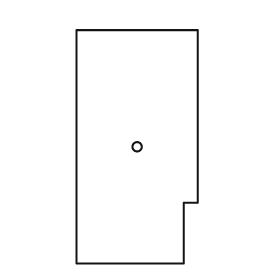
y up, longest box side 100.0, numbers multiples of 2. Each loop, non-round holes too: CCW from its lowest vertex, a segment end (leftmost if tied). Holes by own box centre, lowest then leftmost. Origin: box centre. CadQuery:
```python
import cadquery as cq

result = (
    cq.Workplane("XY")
    .moveTo(-26.0, -50.0)
    .lineTo(20.0, -50.0)
    .lineTo(20.0, -24.0)
    .lineTo(26.0, -24.0)
    .lineTo(26.0, 50.0)
    .lineTo(-26.0, 50.0)
    .close()
    .moveTo(0.0, 0.0)
    .circle(2.0)
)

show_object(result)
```